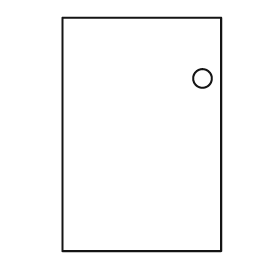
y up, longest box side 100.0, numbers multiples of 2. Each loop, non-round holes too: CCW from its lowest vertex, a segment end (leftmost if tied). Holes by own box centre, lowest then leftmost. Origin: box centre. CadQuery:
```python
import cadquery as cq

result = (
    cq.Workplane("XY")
    .moveTo(-34.0, -50.0)
    .lineTo(34.0, -50.0)
    .lineTo(34.0, 50.0)
    .lineTo(-34.0, 50.0)
    .close()
    .moveTo(26.0, 24.0)
    .circle(4.0)
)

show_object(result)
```